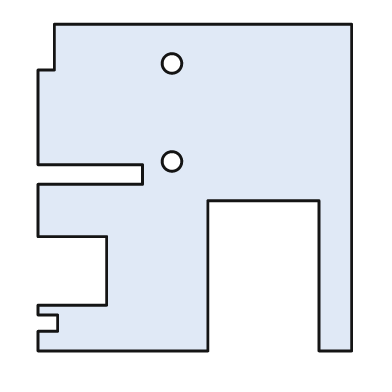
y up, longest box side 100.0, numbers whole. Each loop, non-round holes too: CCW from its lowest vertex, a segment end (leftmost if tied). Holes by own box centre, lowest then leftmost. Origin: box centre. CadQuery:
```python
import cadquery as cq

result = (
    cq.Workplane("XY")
    .moveTo(-48.0, -50.0)
    .lineTo(4.0, -50.0)
    .lineTo(4.0, -4.0)
    .lineTo(38.0, -4.0)
    .lineTo(38.0, -50.0)
    .lineTo(48.0, -50.0)
    .lineTo(48.0, 50.0)
    .lineTo(-43.0, 50.0)
    .lineTo(-43.0, 36.0)
    .lineTo(-48.0, 36.0)
    .lineTo(-48.0, 7.0)
    .lineTo(-16.0, 7.0)
    .lineTo(-16.0, 1.0)
    .lineTo(-48.0, 1.0)
    .lineTo(-48.0, -15.0)
    .lineTo(-27.0, -15.0)
    .lineTo(-27.0, -36.0)
    .lineTo(-48.0, -36.0)
    .lineTo(-48.0, -39.0)
    .lineTo(-42.0, -39.0)
    .lineTo(-42.0, -44.0)
    .lineTo(-48.0, -44.0)
    .close()
    .moveTo(-7.0, 8.0)
    .circle(3.0)
    .moveTo(-7.0, 38.0)
    .circle(3.0)
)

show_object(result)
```